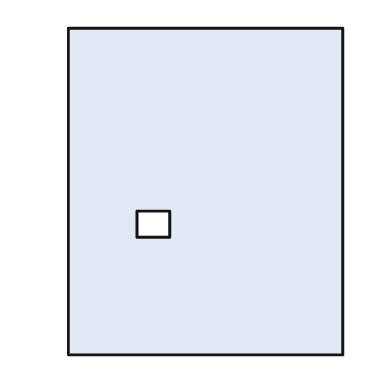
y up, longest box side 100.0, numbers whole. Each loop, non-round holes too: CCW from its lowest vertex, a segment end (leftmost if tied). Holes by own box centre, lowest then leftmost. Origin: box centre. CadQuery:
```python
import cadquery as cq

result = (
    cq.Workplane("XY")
    .moveTo(-42.0, -50.0)
    .lineTo(42.0, -50.0)
    .lineTo(42.0, 50.0)
    .lineTo(-42.0, 50.0)
    .close()
    .moveTo(-21.0, -14.0)
    .lineTo(-11.0, -14.0)
    .lineTo(-11.0, -6.0)
    .lineTo(-21.0, -6.0)
    .close()
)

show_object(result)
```